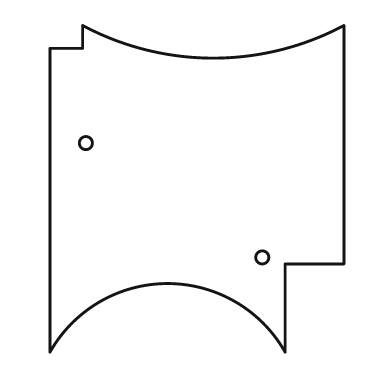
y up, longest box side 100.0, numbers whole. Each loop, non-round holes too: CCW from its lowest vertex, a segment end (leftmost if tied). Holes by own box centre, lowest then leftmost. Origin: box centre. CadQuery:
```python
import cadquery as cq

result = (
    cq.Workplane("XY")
    .moveTo(-45.0, -50.0)
    .threePointArc((-9.0, -29.0), (27.0, -50.0))
    .lineTo(27.0, -23.0)
    .lineTo(45.0, -23.0)
    .lineTo(45.0, 50.0)
    .threePointArc((5.0, 40.0), (-35.0, 50.0))
    .lineTo(-35.0, 43.0)
    .lineTo(-45.0, 43.0)
    .close()
    .moveTo(20.0, -21.0)
    .circle(2.0)
    .moveTo(-34.0, 14.0)
    .circle(2.0)
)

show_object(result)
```